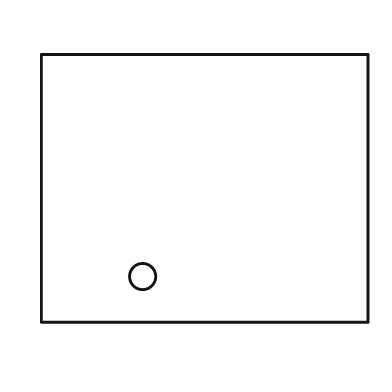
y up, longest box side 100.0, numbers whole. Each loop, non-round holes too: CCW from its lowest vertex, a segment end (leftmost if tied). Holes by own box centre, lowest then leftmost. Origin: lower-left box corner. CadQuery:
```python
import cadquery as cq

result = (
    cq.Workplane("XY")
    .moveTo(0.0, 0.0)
    .lineTo(100.0, 0.0)
    .lineTo(100.0, 82.0)
    .lineTo(0.0, 82.0)
    .close()
    .moveTo(31.0, 14.0)
    .circle(4.0)
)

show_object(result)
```